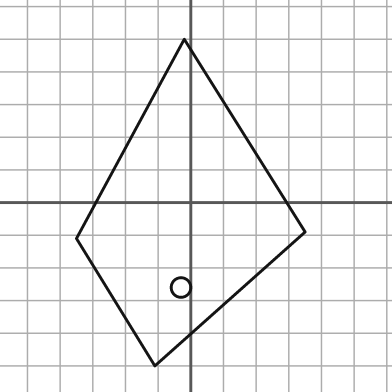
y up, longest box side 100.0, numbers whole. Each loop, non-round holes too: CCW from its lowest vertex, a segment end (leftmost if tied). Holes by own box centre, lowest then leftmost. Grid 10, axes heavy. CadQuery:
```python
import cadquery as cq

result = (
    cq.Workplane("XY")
    .moveTo(-11.0, -50.0)
    .lineTo(35.0, -9.0)
    .lineTo(-2.0, 50.0)
    .lineTo(-35.0, -11.0)
    .close()
    .moveTo(-3.0, -26.0)
    .circle(3.0)
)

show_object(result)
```